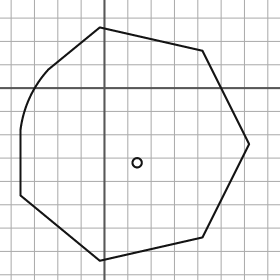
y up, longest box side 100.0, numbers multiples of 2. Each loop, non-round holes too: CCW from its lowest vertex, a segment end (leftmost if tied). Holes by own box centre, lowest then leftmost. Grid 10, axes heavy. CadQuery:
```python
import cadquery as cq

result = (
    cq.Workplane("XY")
    .moveTo(-2.0, -74.0)
    .lineTo(42.0, -64.0)
    .lineTo(62.0, -24.0)
    .lineTo(42.0, 16.0)
    .lineTo(-2.0, 26.0)
    .lineTo(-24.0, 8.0)
    .threePointArc((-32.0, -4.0), (-36.0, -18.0))
    .lineTo(-36.0, -46.0)
    .close()
    .moveTo(14.0, -32.0)
    .circle(2.0)
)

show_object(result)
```